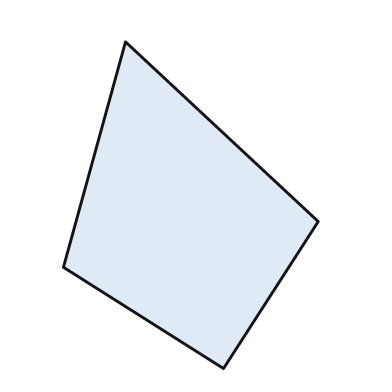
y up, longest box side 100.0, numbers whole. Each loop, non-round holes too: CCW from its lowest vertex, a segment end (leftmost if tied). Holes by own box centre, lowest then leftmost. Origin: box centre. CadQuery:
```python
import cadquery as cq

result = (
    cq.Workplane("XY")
    .moveTo(10.0, -50.0)
    .lineTo(39.0, -5.0)
    .lineTo(-20.0, 50.0)
    .lineTo(-39.0, -19.0)
    .close()
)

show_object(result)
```